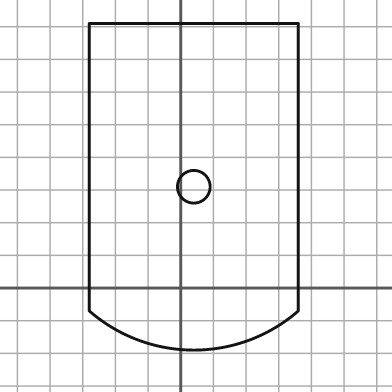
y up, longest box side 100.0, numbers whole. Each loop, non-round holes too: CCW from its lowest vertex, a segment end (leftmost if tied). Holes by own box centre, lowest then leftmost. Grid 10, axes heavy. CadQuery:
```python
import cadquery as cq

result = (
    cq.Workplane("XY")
    .moveTo(-28.0, -7.0)
    .threePointArc((4.0, -19.0), (36.0, -7.0))
    .lineTo(36.0, 81.0)
    .lineTo(-28.0, 81.0)
    .close()
    .moveTo(4.0, 31.0)
    .circle(5.0)
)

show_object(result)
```